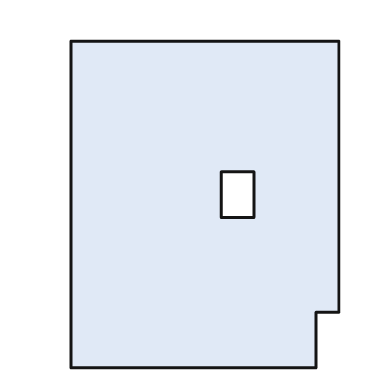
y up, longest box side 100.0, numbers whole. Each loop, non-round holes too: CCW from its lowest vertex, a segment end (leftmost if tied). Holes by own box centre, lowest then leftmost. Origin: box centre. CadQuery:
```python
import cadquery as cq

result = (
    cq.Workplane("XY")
    .moveTo(-41.0, -50.0)
    .lineTo(34.0, -50.0)
    .lineTo(34.0, -33.0)
    .lineTo(41.0, -33.0)
    .lineTo(41.0, 50.0)
    .lineTo(-41.0, 50.0)
    .close()
    .moveTo(5.0, -4.0)
    .lineTo(15.0, -4.0)
    .lineTo(15.0, 10.0)
    .lineTo(5.0, 10.0)
    .close()
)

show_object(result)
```